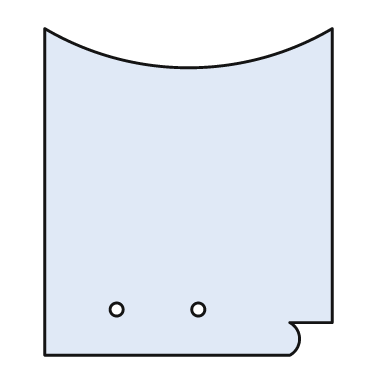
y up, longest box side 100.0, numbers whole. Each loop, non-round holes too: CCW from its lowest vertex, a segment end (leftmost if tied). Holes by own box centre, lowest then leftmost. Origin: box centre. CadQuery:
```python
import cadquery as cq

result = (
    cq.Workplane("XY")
    .moveTo(-44.0, -50.0)
    .lineTo(31.0, -50.0)
    .threePointArc((34.0, -45.0), (31.0, -40.0))
    .lineTo(44.0, -40.0)
    .lineTo(44.0, 50.0)
    .threePointArc((0.0, 38.0), (-44.0, 50.0))
    .close()
    .moveTo(-22.0, -36.0)
    .circle(2.0)
    .moveTo(3.0, -36.0)
    .circle(2.0)
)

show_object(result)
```